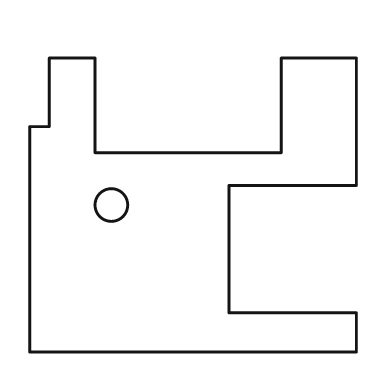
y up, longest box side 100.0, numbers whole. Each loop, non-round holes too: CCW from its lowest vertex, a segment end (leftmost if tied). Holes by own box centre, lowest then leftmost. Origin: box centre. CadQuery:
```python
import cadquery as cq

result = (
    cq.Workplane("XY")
    .moveTo(-50.0, -45.0)
    .lineTo(50.0, -45.0)
    .lineTo(50.0, -33.0)
    .lineTo(11.0, -33.0)
    .lineTo(11.0, 6.0)
    .lineTo(50.0, 6.0)
    .lineTo(50.0, 45.0)
    .lineTo(27.0, 45.0)
    .lineTo(27.0, 16.0)
    .lineTo(-30.0, 16.0)
    .lineTo(-30.0, 45.0)
    .lineTo(-44.0, 45.0)
    .lineTo(-44.0, 24.0)
    .lineTo(-50.0, 24.0)
    .close()
    .moveTo(-25.0, 0.0)
    .circle(5.0)
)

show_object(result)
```